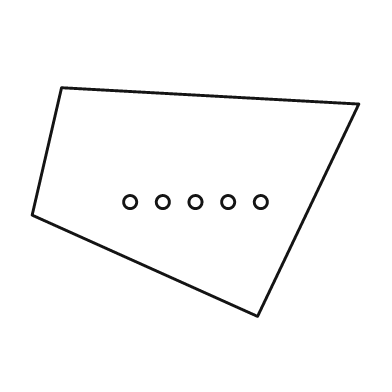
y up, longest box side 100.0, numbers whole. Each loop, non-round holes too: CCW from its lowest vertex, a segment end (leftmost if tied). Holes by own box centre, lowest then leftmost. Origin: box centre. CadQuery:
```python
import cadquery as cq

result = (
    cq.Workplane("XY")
    .moveTo(19.0, -35.0)
    .lineTo(50.0, 30.0)
    .lineTo(-41.0, 35.0)
    .lineTo(-50.0, -4.0)
    .close()
    .moveTo(-20.0, 0.0)
    .circle(2.0)
    .moveTo(-10.0, 0.0)
    .circle(2.0)
    .moveTo(0.0, 0.0)
    .circle(2.0)
    .moveTo(10.0, 0.0)
    .circle(2.0)
    .moveTo(20.0, 0.0)
    .circle(2.0)
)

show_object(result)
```